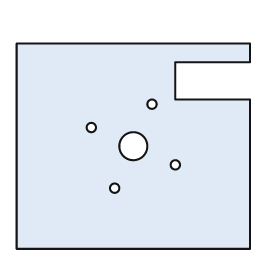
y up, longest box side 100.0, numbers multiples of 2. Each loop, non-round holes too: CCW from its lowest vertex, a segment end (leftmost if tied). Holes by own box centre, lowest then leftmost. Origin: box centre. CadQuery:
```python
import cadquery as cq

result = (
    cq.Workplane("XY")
    .moveTo(-50.0, -44.0)
    .lineTo(50.0, -44.0)
    .lineTo(50.0, 20.0)
    .lineTo(18.0, 20.0)
    .lineTo(18.0, 36.0)
    .lineTo(50.0, 36.0)
    .lineTo(50.0, 44.0)
    .lineTo(-50.0, 44.0)
    .close()
    .moveTo(-8.0, -18.0)
    .circle(2.0)
    .moveTo(18.0, -8.0)
    .circle(2.0)
    .moveTo(0.0, 0.0)
    .circle(6.0)
    .moveTo(-18.0, 8.0)
    .circle(2.0)
    .moveTo(8.0, 18.0)
    .circle(2.0)
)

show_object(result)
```